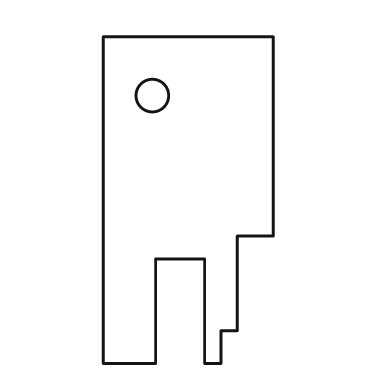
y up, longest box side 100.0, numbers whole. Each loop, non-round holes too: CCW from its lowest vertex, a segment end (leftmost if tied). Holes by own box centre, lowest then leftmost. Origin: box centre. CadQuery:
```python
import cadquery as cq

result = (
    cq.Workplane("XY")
    .moveTo(-26.0, -50.0)
    .lineTo(-10.0, -50.0)
    .lineTo(-10.0, -18.0)
    .lineTo(5.0, -18.0)
    .lineTo(5.0, -50.0)
    .lineTo(10.0, -50.0)
    .lineTo(10.0, -40.0)
    .lineTo(15.0, -40.0)
    .lineTo(15.0, -11.0)
    .lineTo(26.0, -11.0)
    .lineTo(26.0, 50.0)
    .lineTo(-26.0, 50.0)
    .close()
    .moveTo(-11.0, 32.0)
    .circle(5.0)
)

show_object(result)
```